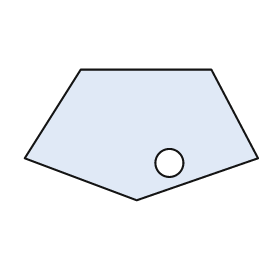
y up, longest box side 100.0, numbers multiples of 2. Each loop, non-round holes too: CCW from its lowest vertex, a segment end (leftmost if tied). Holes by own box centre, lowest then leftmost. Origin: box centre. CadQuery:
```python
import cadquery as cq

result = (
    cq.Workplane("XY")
    .moveTo(-2.0, -28.0)
    .lineTo(50.0, -10.0)
    .lineTo(30.0, 28.0)
    .lineTo(-26.0, 28.0)
    .lineTo(-50.0, -10.0)
    .close()
    .moveTo(12.0, -12.0)
    .circle(6.0)
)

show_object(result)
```